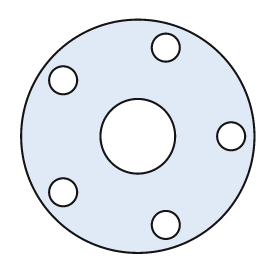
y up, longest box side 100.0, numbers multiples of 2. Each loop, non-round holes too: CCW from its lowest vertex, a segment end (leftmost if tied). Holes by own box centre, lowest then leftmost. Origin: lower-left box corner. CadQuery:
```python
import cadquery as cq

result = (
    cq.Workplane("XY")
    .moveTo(50.0, 50.0)
    .circle(50.0)
    .moveTo(62.0, 12.0)
    .circle(6.0)
    .moveTo(18.0, 26.0)
    .circle(6.0)
    .moveTo(50.0, 50.0)
    .circle(16.0)
    .moveTo(90.0, 50.0)
    .circle(6.0)
    .moveTo(18.0, 74.0)
    .circle(6.0)
    .moveTo(62.0, 88.0)
    .circle(6.0)
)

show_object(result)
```